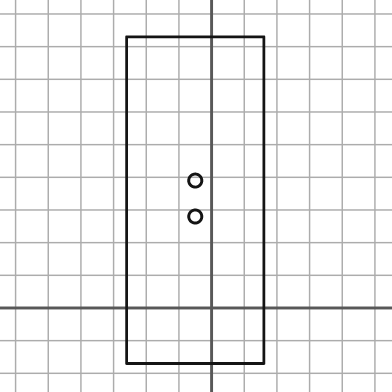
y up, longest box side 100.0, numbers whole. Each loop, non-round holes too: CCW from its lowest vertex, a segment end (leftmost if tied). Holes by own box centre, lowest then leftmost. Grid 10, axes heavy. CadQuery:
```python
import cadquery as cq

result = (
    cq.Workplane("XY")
    .moveTo(-26.0, -17.0)
    .lineTo(16.0, -17.0)
    .lineTo(16.0, 83.0)
    .lineTo(-26.0, 83.0)
    .close()
    .moveTo(-5.0, 28.0)
    .circle(2.0)
    .moveTo(-5.0, 39.0)
    .circle(2.0)
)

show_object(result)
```